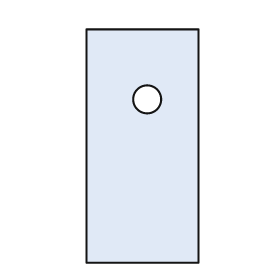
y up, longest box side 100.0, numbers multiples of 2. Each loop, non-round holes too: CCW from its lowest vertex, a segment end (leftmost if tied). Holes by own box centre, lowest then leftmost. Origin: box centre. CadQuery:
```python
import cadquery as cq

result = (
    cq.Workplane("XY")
    .moveTo(-24.0, -50.0)
    .lineTo(24.0, -50.0)
    .lineTo(24.0, 50.0)
    .lineTo(-24.0, 50.0)
    .close()
    .moveTo(2.0, 20.0)
    .circle(6.0)
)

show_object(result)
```